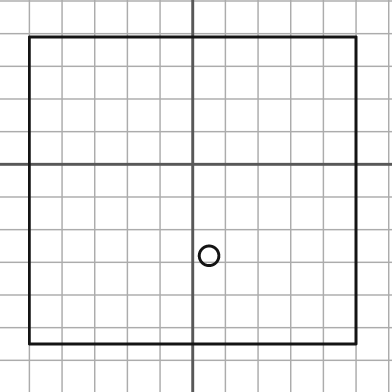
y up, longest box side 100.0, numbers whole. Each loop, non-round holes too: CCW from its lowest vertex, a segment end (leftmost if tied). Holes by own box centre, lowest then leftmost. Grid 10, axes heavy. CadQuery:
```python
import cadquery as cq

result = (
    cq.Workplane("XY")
    .moveTo(-50.0, -55.0)
    .lineTo(50.0, -55.0)
    .lineTo(50.0, 39.0)
    .lineTo(-50.0, 39.0)
    .close()
    .moveTo(5.0, -28.0)
    .circle(3.0)
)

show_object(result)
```